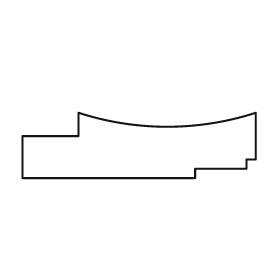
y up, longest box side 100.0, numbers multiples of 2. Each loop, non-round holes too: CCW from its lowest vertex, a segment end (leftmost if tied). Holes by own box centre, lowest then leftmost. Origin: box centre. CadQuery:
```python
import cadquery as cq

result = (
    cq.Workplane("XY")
    .moveTo(-50.0, -14.0)
    .lineTo(24.0, -14.0)
    .lineTo(24.0, -10.0)
    .lineTo(46.0, -10.0)
    .lineTo(46.0, -6.0)
    .lineTo(50.0, -6.0)
    .lineTo(50.0, 14.0)
    .threePointArc((12.0, 8.0), (-26.0, 14.0))
    .lineTo(-26.0, 4.0)
    .lineTo(-50.0, 4.0)
    .close()
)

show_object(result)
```